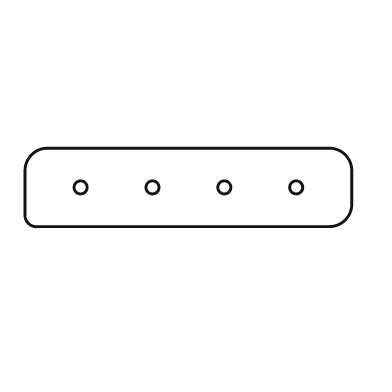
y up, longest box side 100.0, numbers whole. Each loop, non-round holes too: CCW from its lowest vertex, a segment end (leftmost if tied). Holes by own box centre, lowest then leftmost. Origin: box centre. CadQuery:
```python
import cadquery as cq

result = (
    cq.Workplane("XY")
    .moveTo(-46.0, -12.0)
    .lineTo(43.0, -12.0)
    .threePointArc((48.0, -10.0), (50.0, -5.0))
    .lineTo(50.0, 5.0)
    .threePointArc((48.0, 10.0), (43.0, 12.0))
    .lineTo(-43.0, 12.0)
    .threePointArc((-48.0, 10.0), (-50.0, 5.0))
    .lineTo(-50.0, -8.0)
    .threePointArc((-49.0, -11.0), (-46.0, -12.0))
    .close()
    .moveTo(-33.0, 0.0)
    .circle(2.0)
    .moveTo(-11.0, 0.0)
    .circle(2.0)
    .moveTo(11.0, 0.0)
    .circle(2.0)
    .moveTo(33.0, 0.0)
    .circle(2.0)
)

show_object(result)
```